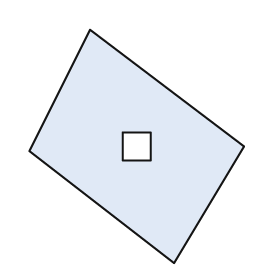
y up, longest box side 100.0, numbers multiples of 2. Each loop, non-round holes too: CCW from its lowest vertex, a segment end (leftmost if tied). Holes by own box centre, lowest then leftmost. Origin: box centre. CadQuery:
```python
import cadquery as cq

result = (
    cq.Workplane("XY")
    .moveTo(16.0, -50.0)
    .lineTo(46.0, 0.0)
    .lineTo(-20.0, 50.0)
    .lineTo(-46.0, -2.0)
    .close()
    .moveTo(-6.0, -6.0)
    .lineTo(6.0, -6.0)
    .lineTo(6.0, 6.0)
    .lineTo(-6.0, 6.0)
    .close()
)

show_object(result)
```